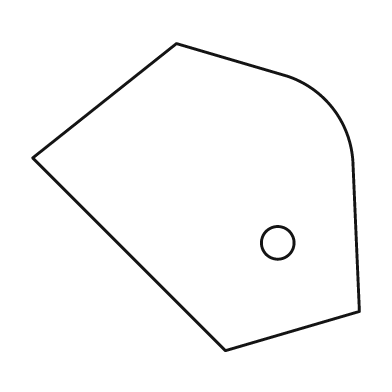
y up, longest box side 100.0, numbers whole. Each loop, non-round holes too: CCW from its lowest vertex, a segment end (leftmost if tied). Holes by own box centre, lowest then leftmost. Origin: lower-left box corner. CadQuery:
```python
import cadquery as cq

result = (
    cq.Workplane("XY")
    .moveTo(59.0, 0.0)
    .lineTo(100.0, 12.0)
    .lineTo(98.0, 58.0)
    .threePointArc((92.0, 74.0), (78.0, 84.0))
    .lineTo(44.0, 94.0)
    .lineTo(0.0, 59.0)
    .close()
    .moveTo(75.0, 33.0)
    .circle(5.0)
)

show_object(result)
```